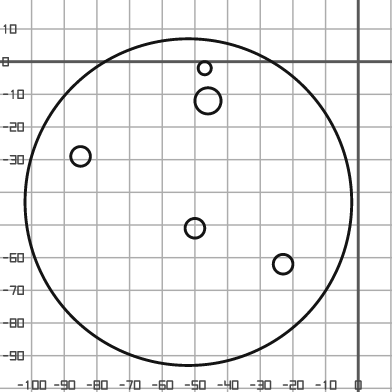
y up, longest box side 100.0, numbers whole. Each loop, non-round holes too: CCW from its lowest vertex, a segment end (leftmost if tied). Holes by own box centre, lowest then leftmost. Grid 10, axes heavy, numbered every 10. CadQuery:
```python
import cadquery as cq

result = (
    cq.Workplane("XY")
    .moveTo(-52.0, -43.0)
    .circle(50.0)
    .moveTo(-23.0, -62.0)
    .circle(3.0)
    .moveTo(-50.0, -51.0)
    .circle(3.0)
    .moveTo(-85.0, -29.0)
    .circle(3.0)
    .moveTo(-46.0, -12.0)
    .circle(4.0)
    .moveTo(-47.0, -2.0)
    .circle(2.0)
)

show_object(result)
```